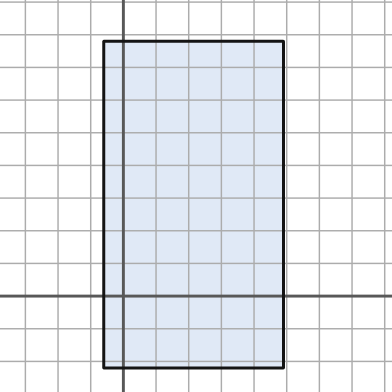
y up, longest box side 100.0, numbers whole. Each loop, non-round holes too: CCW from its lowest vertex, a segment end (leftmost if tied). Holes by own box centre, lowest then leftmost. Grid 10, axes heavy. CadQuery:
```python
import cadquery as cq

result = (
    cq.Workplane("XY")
    .moveTo(-6.0, -22.0)
    .lineTo(49.0, -22.0)
    .lineTo(49.0, 78.0)
    .lineTo(-6.0, 78.0)
    .close()
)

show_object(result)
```